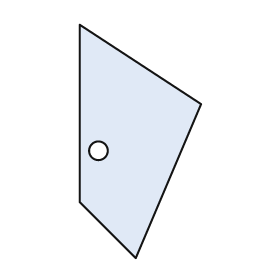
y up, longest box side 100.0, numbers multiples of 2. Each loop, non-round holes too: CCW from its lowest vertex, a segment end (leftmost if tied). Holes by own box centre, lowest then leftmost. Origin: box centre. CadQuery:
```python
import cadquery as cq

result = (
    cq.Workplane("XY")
    .moveTo(-2.0, -50.0)
    .lineTo(26.0, 16.0)
    .lineTo(-26.0, 50.0)
    .lineTo(-26.0, -26.0)
    .close()
    .moveTo(-18.0, -4.0)
    .circle(4.0)
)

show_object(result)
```